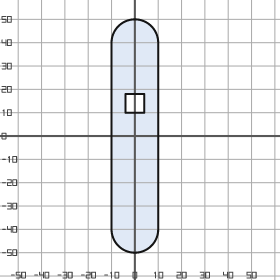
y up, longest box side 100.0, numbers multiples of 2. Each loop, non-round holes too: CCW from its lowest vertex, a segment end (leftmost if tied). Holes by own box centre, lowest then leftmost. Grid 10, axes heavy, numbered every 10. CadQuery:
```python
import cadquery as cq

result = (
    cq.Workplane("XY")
    .moveTo(-10.0, -40.0)
    .threePointArc((0.0, -50.0), (10.0, -40.0))
    .lineTo(10.0, 40.0)
    .threePointArc((0.0, 50.0), (-10.0, 40.0))
    .close()
    .moveTo(-4.0, 10.0)
    .lineTo(4.0, 10.0)
    .lineTo(4.0, 18.0)
    .lineTo(-4.0, 18.0)
    .close()
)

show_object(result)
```